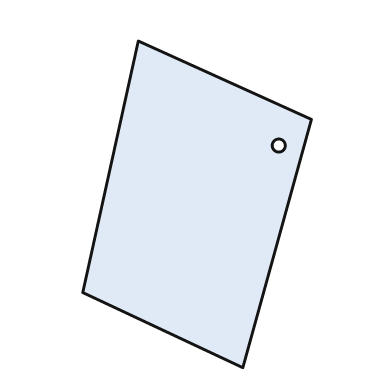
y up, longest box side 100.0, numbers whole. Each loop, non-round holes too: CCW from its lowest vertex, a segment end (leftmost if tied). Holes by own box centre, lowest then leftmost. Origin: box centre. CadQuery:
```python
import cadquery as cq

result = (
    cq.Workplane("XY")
    .moveTo(14.0, -50.0)
    .lineTo(35.0, 26.0)
    .lineTo(-18.0, 50.0)
    .lineTo(-35.0, -27.0)
    .close()
    .moveTo(25.0, 18.0)
    .circle(2.0)
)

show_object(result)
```